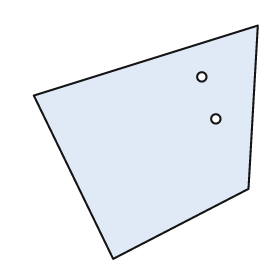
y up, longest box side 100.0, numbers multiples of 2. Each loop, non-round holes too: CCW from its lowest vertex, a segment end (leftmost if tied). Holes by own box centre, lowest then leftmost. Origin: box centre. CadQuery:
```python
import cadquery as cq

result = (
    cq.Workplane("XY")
    .moveTo(-14.0, -50.0)
    .lineTo(44.0, -20.0)
    .lineTo(48.0, 50.0)
    .lineTo(-48.0, 20.0)
    .close()
    .moveTo(30.0, 10.0)
    .circle(2.0)
    .moveTo(24.0, 28.0)
    .circle(2.0)
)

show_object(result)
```